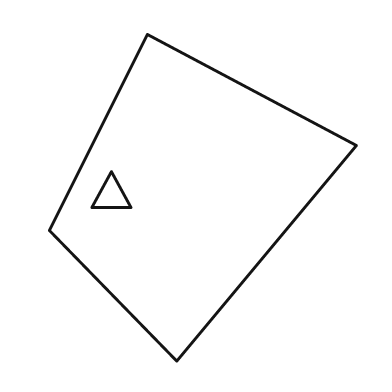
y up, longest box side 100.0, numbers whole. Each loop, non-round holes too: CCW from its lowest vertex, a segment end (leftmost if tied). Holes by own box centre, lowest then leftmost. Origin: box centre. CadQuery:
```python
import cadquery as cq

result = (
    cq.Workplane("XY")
    .moveTo(-8.0, -50.0)
    .lineTo(47.0, 16.0)
    .lineTo(-17.0, 50.0)
    .lineTo(-47.0, -10.0)
    .close()
    .moveTo(-34.0, -3.0)
    .lineTo(-22.0, -3.0)
    .lineTo(-28.0, 8.0)
    .close()
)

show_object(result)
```